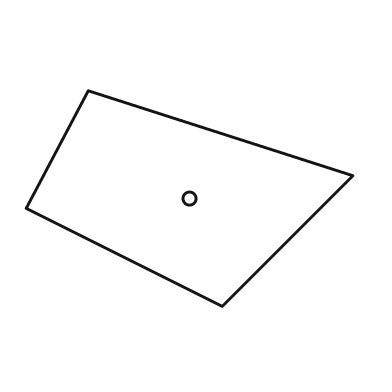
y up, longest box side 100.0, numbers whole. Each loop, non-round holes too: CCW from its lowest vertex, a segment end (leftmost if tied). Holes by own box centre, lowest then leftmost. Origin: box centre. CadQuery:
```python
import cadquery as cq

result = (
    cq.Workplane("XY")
    .moveTo(10.0, -33.0)
    .lineTo(50.0, 7.0)
    .lineTo(-31.0, 33.0)
    .lineTo(-50.0, -3.0)
    .close()
    .moveTo(0.0, 0.0)
    .circle(2.0)
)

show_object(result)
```